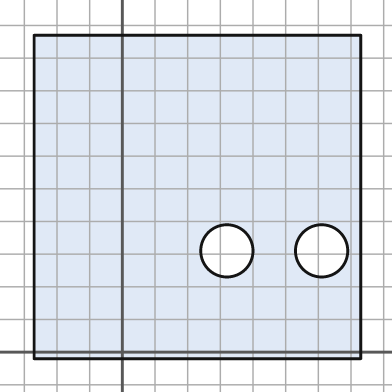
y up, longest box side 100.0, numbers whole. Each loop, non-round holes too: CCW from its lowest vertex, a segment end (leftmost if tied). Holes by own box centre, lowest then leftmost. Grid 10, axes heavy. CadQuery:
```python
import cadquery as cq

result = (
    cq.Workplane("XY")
    .moveTo(-27.0, -2.0)
    .lineTo(73.0, -2.0)
    .lineTo(73.0, 97.0)
    .lineTo(-27.0, 97.0)
    .close()
    .moveTo(32.0, 31.0)
    .circle(8.0)
    .moveTo(61.0, 31.0)
    .circle(8.0)
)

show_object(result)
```